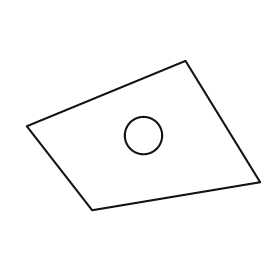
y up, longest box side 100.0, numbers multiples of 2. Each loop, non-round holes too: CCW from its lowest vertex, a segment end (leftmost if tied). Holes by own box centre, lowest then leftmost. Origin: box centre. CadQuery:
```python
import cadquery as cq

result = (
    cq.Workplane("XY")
    .moveTo(-22.0, -32.0)
    .lineTo(50.0, -20.0)
    .lineTo(18.0, 32.0)
    .lineTo(-50.0, 4.0)
    .close()
    .moveTo(0.0, 0.0)
    .circle(8.0)
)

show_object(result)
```